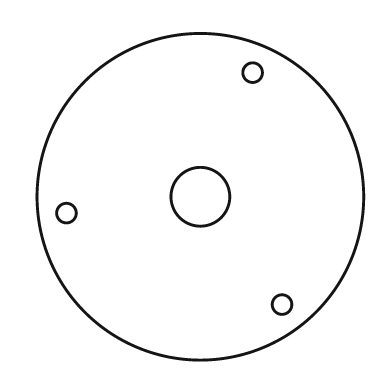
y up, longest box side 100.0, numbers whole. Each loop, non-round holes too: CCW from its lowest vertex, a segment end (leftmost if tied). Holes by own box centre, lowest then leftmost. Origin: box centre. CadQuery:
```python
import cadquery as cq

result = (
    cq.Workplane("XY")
    .moveTo(0.0, 0.0)
    .circle(50.0)
    .moveTo(25.0, -33.0)
    .circle(3.0)
    .moveTo(-41.0, -5.0)
    .circle(3.0)
    .moveTo(0.0, 0.0)
    .circle(9.0)
    .moveTo(16.0, 38.0)
    .circle(3.0)
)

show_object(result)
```